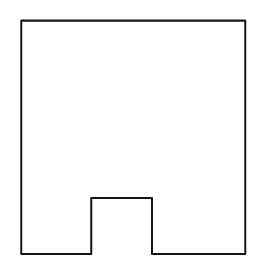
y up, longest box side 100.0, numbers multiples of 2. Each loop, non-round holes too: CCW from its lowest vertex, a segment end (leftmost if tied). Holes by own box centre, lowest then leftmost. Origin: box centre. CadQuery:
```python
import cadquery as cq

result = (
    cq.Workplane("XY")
    .moveTo(-48.0, -50.0)
    .lineTo(-18.0, -50.0)
    .lineTo(-18.0, -26.0)
    .lineTo(8.0, -26.0)
    .lineTo(8.0, -50.0)
    .lineTo(48.0, -50.0)
    .lineTo(48.0, 50.0)
    .lineTo(-48.0, 50.0)
    .close()
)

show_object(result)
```